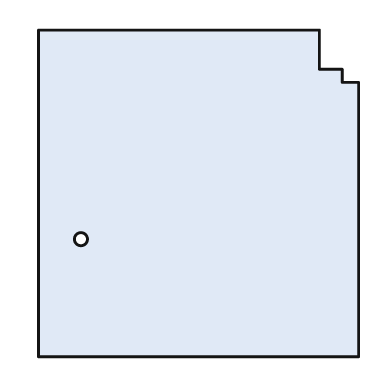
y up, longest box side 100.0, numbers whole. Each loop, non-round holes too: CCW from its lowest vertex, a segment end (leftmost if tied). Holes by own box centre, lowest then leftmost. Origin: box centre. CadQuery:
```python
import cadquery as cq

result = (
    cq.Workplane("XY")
    .moveTo(-49.0, -50.0)
    .lineTo(49.0, -50.0)
    .lineTo(49.0, 34.0)
    .lineTo(44.0, 34.0)
    .lineTo(44.0, 38.0)
    .lineTo(37.0, 38.0)
    .lineTo(37.0, 50.0)
    .lineTo(-49.0, 50.0)
    .close()
    .moveTo(-36.0, -14.0)
    .circle(2.0)
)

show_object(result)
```